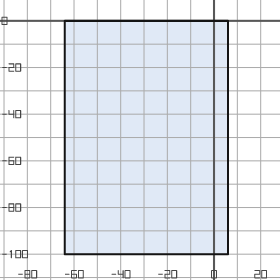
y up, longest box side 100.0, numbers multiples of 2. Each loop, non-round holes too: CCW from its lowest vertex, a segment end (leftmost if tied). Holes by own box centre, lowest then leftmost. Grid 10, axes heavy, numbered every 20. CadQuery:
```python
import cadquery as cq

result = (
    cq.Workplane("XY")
    .moveTo(-64.0, -100.0)
    .lineTo(6.0, -100.0)
    .lineTo(6.0, 0.0)
    .lineTo(-64.0, 0.0)
    .close()
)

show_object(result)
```